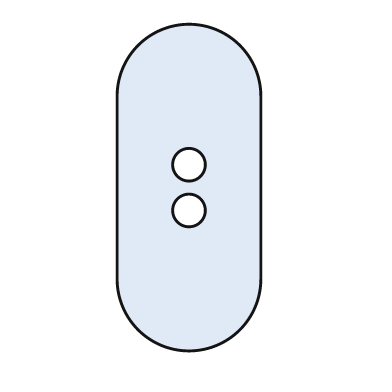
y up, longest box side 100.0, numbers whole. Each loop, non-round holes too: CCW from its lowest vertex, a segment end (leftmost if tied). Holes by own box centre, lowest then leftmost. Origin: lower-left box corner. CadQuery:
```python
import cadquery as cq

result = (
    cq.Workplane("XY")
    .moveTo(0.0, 22.0)
    .threePointArc((22.0, 0.0), (44.0, 22.0))
    .lineTo(44.0, 78.0)
    .threePointArc((22.0, 100.0), (0.0, 78.0))
    .close()
    .moveTo(22.0, 43.0)
    .circle(5.0)
    .moveTo(22.0, 57.0)
    .circle(5.0)
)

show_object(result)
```